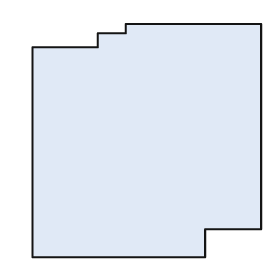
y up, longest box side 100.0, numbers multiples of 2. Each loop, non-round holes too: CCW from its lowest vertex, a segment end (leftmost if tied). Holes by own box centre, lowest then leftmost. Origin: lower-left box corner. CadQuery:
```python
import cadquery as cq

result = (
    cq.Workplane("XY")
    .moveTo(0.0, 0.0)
    .lineTo(74.0, 0.0)
    .lineTo(74.0, 12.0)
    .lineTo(98.0, 12.0)
    .lineTo(98.0, 100.0)
    .lineTo(40.0, 100.0)
    .lineTo(40.0, 96.0)
    .lineTo(28.0, 96.0)
    .lineTo(28.0, 90.0)
    .lineTo(0.0, 90.0)
    .close()
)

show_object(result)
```